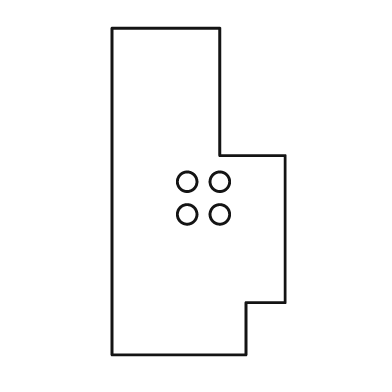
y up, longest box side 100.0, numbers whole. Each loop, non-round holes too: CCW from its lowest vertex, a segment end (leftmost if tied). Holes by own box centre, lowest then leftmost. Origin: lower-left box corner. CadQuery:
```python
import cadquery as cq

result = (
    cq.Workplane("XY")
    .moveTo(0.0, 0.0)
    .lineTo(41.0, 0.0)
    .lineTo(41.0, 16.0)
    .lineTo(53.0, 16.0)
    .lineTo(53.0, 61.0)
    .lineTo(33.0, 61.0)
    .lineTo(33.0, 100.0)
    .lineTo(0.0, 100.0)
    .close()
    .moveTo(23.0, 43.0)
    .circle(3.0)
    .moveTo(33.0, 43.0)
    .circle(3.0)
    .moveTo(23.0, 53.0)
    .circle(3.0)
    .moveTo(33.0, 53.0)
    .circle(3.0)
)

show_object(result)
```